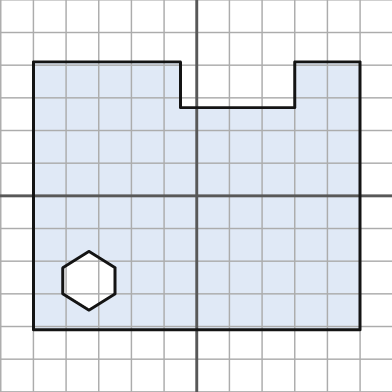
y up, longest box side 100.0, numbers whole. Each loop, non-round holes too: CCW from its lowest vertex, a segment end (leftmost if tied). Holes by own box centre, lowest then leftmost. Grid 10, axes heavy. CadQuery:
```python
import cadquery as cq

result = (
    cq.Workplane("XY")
    .moveTo(-50.0, -41.0)
    .lineTo(50.0, -41.0)
    .lineTo(50.0, 41.0)
    .lineTo(30.0, 41.0)
    .lineTo(30.0, 27.0)
    .lineTo(-5.0, 27.0)
    .lineTo(-5.0, 41.0)
    .lineTo(-50.0, 41.0)
    .close()
    .moveTo(-33.0, -35.0)
    .lineTo(-25.0, -30.0)
    .lineTo(-25.0, -22.0)
    .lineTo(-33.0, -17.0)
    .lineTo(-41.0, -22.0)
    .lineTo(-41.0, -30.0)
    .close()
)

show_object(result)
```